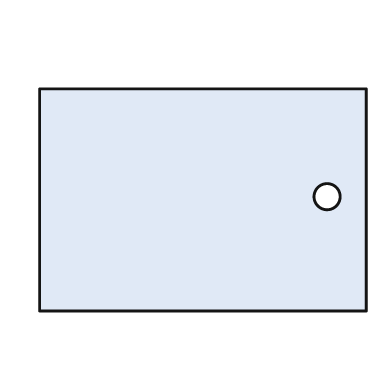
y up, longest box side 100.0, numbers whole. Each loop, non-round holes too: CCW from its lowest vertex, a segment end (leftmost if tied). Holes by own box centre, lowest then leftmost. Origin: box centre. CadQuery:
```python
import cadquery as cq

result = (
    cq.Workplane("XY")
    .moveTo(-50.0, -34.0)
    .lineTo(50.0, -34.0)
    .lineTo(50.0, 34.0)
    .lineTo(-50.0, 34.0)
    .close()
    .moveTo(38.0, 1.0)
    .circle(4.0)
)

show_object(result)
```